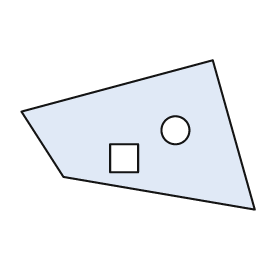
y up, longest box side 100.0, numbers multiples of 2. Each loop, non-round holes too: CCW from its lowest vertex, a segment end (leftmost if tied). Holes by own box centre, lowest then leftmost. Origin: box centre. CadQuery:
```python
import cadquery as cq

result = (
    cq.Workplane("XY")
    .moveTo(50.0, -32.0)
    .lineTo(32.0, 32.0)
    .lineTo(-50.0, 10.0)
    .lineTo(-32.0, -18.0)
    .close()
    .moveTo(-12.0, -16.0)
    .lineTo(0.0, -16.0)
    .lineTo(0.0, -4.0)
    .lineTo(-12.0, -4.0)
    .close()
    .moveTo(16.0, 2.0)
    .circle(6.0)
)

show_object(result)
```